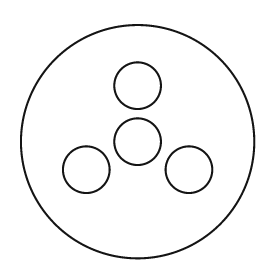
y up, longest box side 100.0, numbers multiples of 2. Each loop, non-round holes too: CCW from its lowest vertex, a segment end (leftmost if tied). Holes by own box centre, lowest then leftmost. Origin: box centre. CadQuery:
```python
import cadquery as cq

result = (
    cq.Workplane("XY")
    .moveTo(0.0, 0.0)
    .circle(50.0)
    .moveTo(-22.0, -12.0)
    .circle(10.0)
    .moveTo(22.0, -12.0)
    .circle(10.0)
    .moveTo(0.0, 0.0)
    .circle(10.0)
    .moveTo(0.0, 24.0)
    .circle(10.0)
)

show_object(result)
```